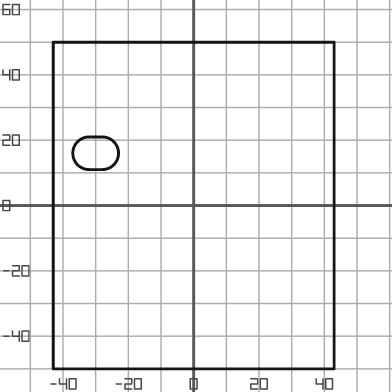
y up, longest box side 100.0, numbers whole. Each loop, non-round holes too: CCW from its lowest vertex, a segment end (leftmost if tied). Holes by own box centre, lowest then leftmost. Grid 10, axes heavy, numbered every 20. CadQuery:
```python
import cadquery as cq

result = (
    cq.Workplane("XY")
    .moveTo(-43.0, -50.0)
    .lineTo(43.0, -50.0)
    .lineTo(43.0, 50.0)
    .lineTo(-43.0, 50.0)
    .close()
    .moveTo(-32.0, 11.0)
    .lineTo(-28.0, 11.0)
    .threePointArc((-23.0, 16.0), (-28.0, 21.0))
    .lineTo(-32.0, 21.0)
    .threePointArc((-37.0, 16.0), (-32.0, 11.0))
    .close()
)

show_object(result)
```